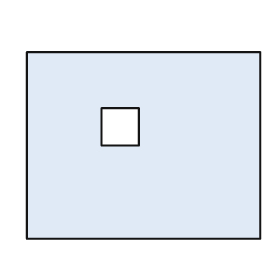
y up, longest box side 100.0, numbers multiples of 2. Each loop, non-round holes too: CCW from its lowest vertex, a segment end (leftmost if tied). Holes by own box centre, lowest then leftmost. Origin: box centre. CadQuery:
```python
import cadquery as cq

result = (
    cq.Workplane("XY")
    .moveTo(-50.0, -40.0)
    .lineTo(50.0, -40.0)
    .lineTo(50.0, 40.0)
    .lineTo(-50.0, 40.0)
    .close()
    .moveTo(-18.0, 0.0)
    .lineTo(-2.0, 0.0)
    .lineTo(-2.0, 16.0)
    .lineTo(-18.0, 16.0)
    .close()
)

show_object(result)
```